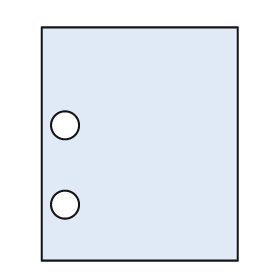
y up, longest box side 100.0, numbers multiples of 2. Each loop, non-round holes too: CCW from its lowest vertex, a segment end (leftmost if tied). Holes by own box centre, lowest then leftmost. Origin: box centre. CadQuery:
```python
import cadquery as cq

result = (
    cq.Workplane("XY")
    .moveTo(-42.0, -50.0)
    .lineTo(42.0, -50.0)
    .lineTo(42.0, 50.0)
    .lineTo(-42.0, 50.0)
    .close()
    .moveTo(-32.0, -26.0)
    .circle(6.0)
    .moveTo(-32.0, 8.0)
    .circle(6.0)
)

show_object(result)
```